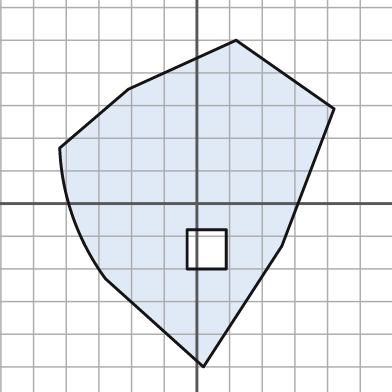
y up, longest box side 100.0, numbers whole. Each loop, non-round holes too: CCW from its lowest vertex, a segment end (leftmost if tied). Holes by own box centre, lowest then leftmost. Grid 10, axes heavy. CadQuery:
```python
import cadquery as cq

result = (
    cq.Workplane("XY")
    .moveTo(2.0, -50.0)
    .lineTo(26.0, -13.0)
    .lineTo(42.0, 29.0)
    .lineTo(12.0, 50.0)
    .lineTo(-21.0, 35.0)
    .lineTo(-42.0, 17.0)
    .threePointArc((-38.0, -4.0), (-28.0, -23.0))
    .close()
    .moveTo(-3.0, -20.0)
    .lineTo(9.0, -20.0)
    .lineTo(9.0, -8.0)
    .lineTo(-3.0, -8.0)
    .close()
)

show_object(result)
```